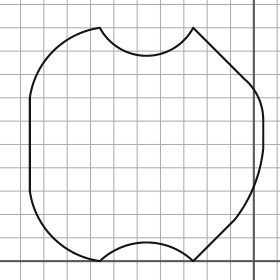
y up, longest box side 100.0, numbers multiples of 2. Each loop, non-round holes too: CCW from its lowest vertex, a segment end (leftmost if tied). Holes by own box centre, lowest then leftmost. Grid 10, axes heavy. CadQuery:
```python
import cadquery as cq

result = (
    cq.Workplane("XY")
    .moveTo(-66.0, 0.0)
    .threePointArc((-46.0, 8.0), (-26.0, 0.0))
    .lineTo(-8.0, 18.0)
    .threePointArc((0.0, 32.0), (4.0, 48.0))
    .lineTo(4.0, 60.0)
    .threePointArc((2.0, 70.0), (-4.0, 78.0))
    .lineTo(-26.0, 100.0)
    .threePointArc((-46.0, 88.0), (-66.0, 100.0))
    .threePointArc((-86.0, 90.0), (-96.0, 70.0))
    .lineTo(-96.0, 30.0)
    .threePointArc((-86.0, 10.0), (-66.0, 0.0))
    .close()
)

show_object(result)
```